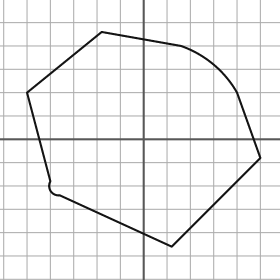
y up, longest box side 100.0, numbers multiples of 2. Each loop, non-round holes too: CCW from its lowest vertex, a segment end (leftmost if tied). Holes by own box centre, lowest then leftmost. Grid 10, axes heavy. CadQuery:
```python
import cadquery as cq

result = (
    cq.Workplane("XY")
    .moveTo(12.0, -46.0)
    .lineTo(50.0, -8.0)
    .lineTo(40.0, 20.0)
    .threePointArc((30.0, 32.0), (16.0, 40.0))
    .lineTo(-18.0, 46.0)
    .lineTo(-50.0, 20.0)
    .lineTo(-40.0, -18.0)
    .threePointArc((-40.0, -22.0), (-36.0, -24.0))
    .close()
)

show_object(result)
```